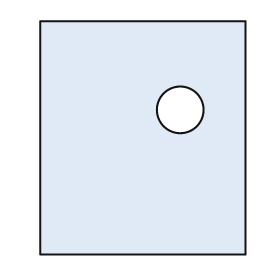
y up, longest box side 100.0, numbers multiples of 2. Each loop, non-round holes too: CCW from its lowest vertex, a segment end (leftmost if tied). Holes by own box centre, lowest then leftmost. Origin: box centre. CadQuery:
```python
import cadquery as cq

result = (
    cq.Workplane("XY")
    .moveTo(-44.0, -50.0)
    .lineTo(44.0, -50.0)
    .lineTo(44.0, 50.0)
    .lineTo(-44.0, 50.0)
    .close()
    .moveTo(16.0, 12.0)
    .circle(10.0)
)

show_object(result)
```